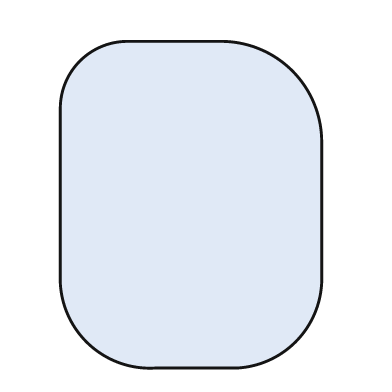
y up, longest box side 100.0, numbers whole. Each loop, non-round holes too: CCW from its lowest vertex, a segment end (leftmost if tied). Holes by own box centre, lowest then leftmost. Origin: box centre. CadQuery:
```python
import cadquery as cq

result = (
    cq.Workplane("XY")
    .moveTo(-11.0, -50.0)
    .lineTo(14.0, -50.0)
    .threePointArc((32.0, -42.0), (40.0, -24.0))
    .lineTo(40.0, 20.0)
    .threePointArc((31.0, 41.0), (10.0, 50.0))
    .lineTo(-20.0, 50.0)
    .threePointArc((-34.0, 44.0), (-40.0, 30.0))
    .lineTo(-40.0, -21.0)
    .threePointArc((-32.0, -42.0), (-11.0, -50.0))
    .close()
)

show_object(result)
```